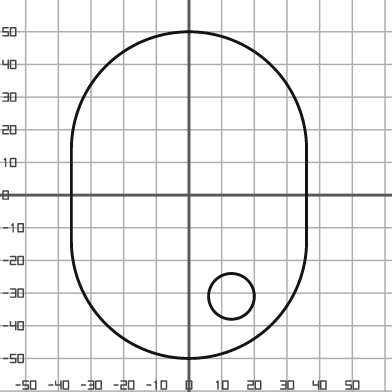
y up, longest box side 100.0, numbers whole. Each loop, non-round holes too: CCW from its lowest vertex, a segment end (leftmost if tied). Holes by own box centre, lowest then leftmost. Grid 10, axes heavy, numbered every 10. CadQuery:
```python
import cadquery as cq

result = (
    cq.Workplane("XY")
    .moveTo(-36.0, -14.0)
    .threePointArc((0.0, -50.0), (36.0, -14.0))
    .lineTo(36.0, 14.0)
    .threePointArc((0.0, 50.0), (-36.0, 14.0))
    .close()
    .moveTo(13.0, -31.0)
    .circle(7.0)
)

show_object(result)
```